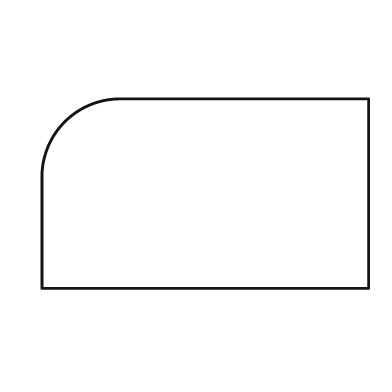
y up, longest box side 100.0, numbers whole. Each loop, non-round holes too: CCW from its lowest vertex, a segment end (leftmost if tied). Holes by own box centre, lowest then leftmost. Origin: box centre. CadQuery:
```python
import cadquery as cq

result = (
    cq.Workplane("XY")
    .moveTo(-50.0, -29.0)
    .lineTo(50.0, -29.0)
    .lineTo(50.0, 29.0)
    .lineTo(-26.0, 29.0)
    .threePointArc((-43.0, 22.0), (-50.0, 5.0))
    .close()
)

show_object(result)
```